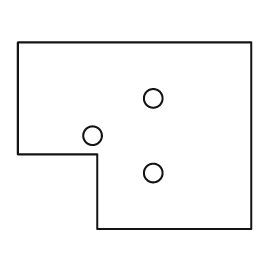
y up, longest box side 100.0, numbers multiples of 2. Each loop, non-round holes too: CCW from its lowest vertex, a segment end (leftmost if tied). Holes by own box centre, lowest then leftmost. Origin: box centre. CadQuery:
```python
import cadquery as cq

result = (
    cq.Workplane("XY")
    .moveTo(-16.0, -40.0)
    .lineTo(50.0, -40.0)
    .lineTo(50.0, 40.0)
    .lineTo(-50.0, 40.0)
    .lineTo(-50.0, -8.0)
    .lineTo(-16.0, -8.0)
    .close()
    .moveTo(8.0, -16.0)
    .circle(4.0)
    .moveTo(-18.0, 0.0)
    .circle(4.0)
    .moveTo(8.0, 16.0)
    .circle(4.0)
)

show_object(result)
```